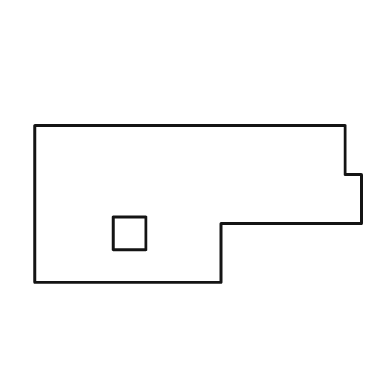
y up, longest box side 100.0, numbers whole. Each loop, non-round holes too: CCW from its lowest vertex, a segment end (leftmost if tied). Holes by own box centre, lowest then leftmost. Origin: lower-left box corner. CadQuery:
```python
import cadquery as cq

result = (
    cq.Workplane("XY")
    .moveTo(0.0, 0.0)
    .lineTo(57.0, 0.0)
    .lineTo(57.0, 18.0)
    .lineTo(100.0, 18.0)
    .lineTo(100.0, 33.0)
    .lineTo(95.0, 33.0)
    .lineTo(95.0, 48.0)
    .lineTo(0.0, 48.0)
    .close()
    .moveTo(24.0, 10.0)
    .lineTo(34.0, 10.0)
    .lineTo(34.0, 20.0)
    .lineTo(24.0, 20.0)
    .close()
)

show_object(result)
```